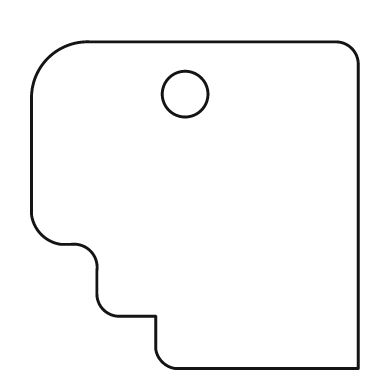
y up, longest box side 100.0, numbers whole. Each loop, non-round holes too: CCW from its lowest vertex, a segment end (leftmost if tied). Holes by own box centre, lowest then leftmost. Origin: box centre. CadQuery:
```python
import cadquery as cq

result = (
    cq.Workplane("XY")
    .moveTo(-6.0, -50.0)
    .lineTo(50.0, -50.0)
    .lineTo(50.0, 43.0)
    .threePointArc((48.0, 48.0), (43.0, 50.0))
    .lineTo(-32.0, 50.0)
    .threePointArc((-45.0, 45.0), (-50.0, 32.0))
    .lineTo(-50.0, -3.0)
    .threePointArc((-47.0, -9.0), (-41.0, -12.0))
    .lineTo(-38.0, -12.0)
    .threePointArc((-32.0, -14.0), (-30.0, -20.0))
    .lineTo(-30.0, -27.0)
    .threePointArc((-28.0, -32.0), (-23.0, -34.0))
    .lineTo(-12.0, -34.0)
    .lineTo(-12.0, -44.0)
    .threePointArc((-10.0, -48.0), (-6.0, -50.0))
    .close()
    .moveTo(-3.0, 34.0)
    .circle(7.0)
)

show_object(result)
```